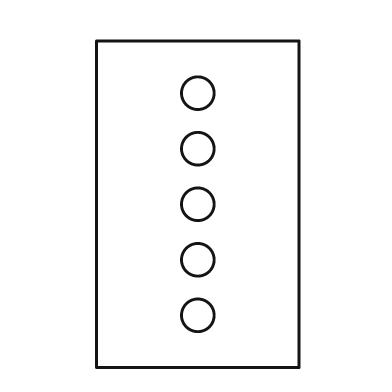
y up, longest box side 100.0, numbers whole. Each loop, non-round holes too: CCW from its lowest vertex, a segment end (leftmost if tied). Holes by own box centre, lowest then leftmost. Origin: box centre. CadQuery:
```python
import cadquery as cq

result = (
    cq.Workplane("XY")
    .moveTo(-31.0, -50.0)
    .lineTo(31.0, -50.0)
    .lineTo(31.0, 50.0)
    .lineTo(-31.0, 50.0)
    .close()
    .moveTo(0.0, -34.0)
    .circle(5.0)
    .moveTo(0.0, -17.0)
    .circle(5.0)
    .moveTo(0.0, 0.0)
    .circle(5.0)
    .moveTo(0.0, 17.0)
    .circle(5.0)
    .moveTo(0.0, 34.0)
    .circle(5.0)
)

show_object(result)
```